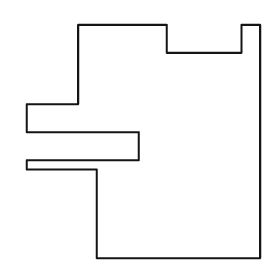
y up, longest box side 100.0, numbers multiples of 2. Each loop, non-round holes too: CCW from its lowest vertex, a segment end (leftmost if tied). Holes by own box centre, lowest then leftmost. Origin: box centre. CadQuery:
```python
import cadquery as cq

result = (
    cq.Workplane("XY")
    .moveTo(-20.0, -50.0)
    .lineTo(50.0, -50.0)
    .lineTo(50.0, 50.0)
    .lineTo(42.0, 50.0)
    .lineTo(42.0, 38.0)
    .lineTo(10.0, 38.0)
    .lineTo(10.0, 50.0)
    .lineTo(-28.0, 50.0)
    .lineTo(-28.0, 16.0)
    .lineTo(-50.0, 16.0)
    .lineTo(-50.0, 4.0)
    .lineTo(-2.0, 4.0)
    .lineTo(-2.0, -8.0)
    .lineTo(-50.0, -8.0)
    .lineTo(-50.0, -12.0)
    .lineTo(-20.0, -12.0)
    .close()
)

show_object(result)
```